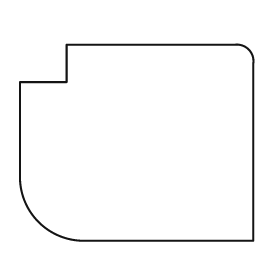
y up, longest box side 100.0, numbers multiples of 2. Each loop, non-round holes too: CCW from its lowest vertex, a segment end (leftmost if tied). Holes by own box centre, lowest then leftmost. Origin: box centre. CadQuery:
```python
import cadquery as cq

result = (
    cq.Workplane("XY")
    .moveTo(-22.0, -42.0)
    .lineTo(50.0, -42.0)
    .lineTo(50.0, 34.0)
    .threePointArc((48.0, 40.0), (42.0, 42.0))
    .lineTo(-30.0, 42.0)
    .lineTo(-30.0, 26.0)
    .lineTo(-50.0, 26.0)
    .lineTo(-50.0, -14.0)
    .threePointArc((-42.0, -34.0), (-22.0, -42.0))
    .close()
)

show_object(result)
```